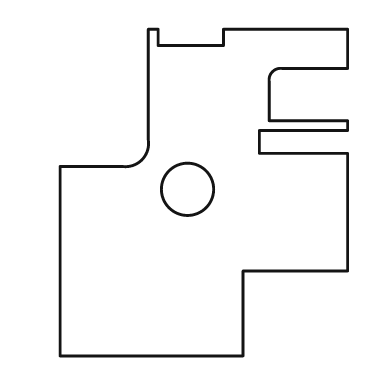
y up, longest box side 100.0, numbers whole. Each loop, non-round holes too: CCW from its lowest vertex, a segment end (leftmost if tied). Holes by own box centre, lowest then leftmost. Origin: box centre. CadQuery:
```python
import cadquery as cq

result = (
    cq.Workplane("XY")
    .moveTo(-44.0, -50.0)
    .lineTo(12.0, -50.0)
    .lineTo(12.0, -24.0)
    .lineTo(44.0, -24.0)
    .lineTo(44.0, 12.0)
    .lineTo(17.0, 12.0)
    .lineTo(17.0, 19.0)
    .lineTo(44.0, 19.0)
    .lineTo(44.0, 22.0)
    .lineTo(20.0, 22.0)
    .lineTo(20.0, 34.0)
    .threePointArc((21.0, 37.0), (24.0, 38.0))
    .lineTo(44.0, 38.0)
    .lineTo(44.0, 50.0)
    .lineTo(6.0, 50.0)
    .lineTo(6.0, 45.0)
    .lineTo(-14.0, 45.0)
    .lineTo(-14.0, 50.0)
    .lineTo(-17.0, 50.0)
    .lineTo(-17.0, 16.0)
    .threePointArc((-19.0, 10.0), (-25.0, 8.0))
    .lineTo(-44.0, 8.0)
    .close()
    .moveTo(-5.0, 1.0)
    .circle(8.0)
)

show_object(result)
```